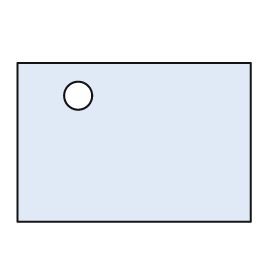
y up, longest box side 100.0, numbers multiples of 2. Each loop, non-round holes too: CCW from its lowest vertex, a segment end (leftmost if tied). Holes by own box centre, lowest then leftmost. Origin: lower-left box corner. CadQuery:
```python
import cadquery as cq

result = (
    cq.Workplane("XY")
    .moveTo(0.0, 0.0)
    .lineTo(100.0, 0.0)
    .lineTo(100.0, 68.0)
    .lineTo(0.0, 68.0)
    .close()
    .moveTo(26.0, 54.0)
    .circle(6.0)
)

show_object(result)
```